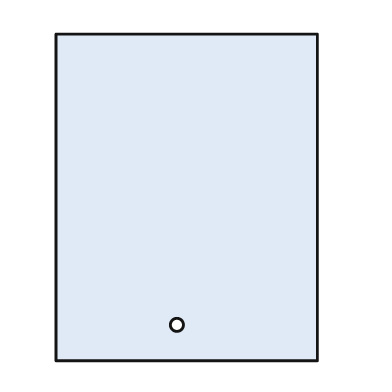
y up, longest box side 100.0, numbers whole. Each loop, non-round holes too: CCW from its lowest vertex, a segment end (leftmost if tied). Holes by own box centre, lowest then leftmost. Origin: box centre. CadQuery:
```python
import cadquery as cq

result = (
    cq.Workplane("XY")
    .moveTo(-40.0, -50.0)
    .lineTo(40.0, -50.0)
    .lineTo(40.0, 50.0)
    .lineTo(-40.0, 50.0)
    .close()
    .moveTo(-3.0, -39.0)
    .circle(2.0)
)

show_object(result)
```